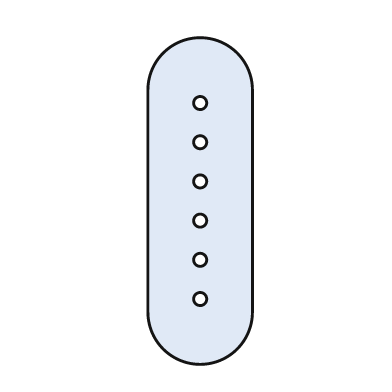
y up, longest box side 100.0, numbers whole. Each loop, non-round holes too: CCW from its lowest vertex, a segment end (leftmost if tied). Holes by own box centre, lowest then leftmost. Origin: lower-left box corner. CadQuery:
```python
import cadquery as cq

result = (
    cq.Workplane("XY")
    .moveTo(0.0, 16.0)
    .threePointArc((16.0, 0.0), (32.0, 16.0))
    .lineTo(32.0, 84.0)
    .threePointArc((16.0, 100.0), (0.0, 84.0))
    .close()
    .moveTo(16.0, 20.0)
    .circle(2.0)
    .moveTo(16.0, 32.0)
    .circle(2.0)
    .moveTo(16.0, 44.0)
    .circle(2.0)
    .moveTo(16.0, 56.0)
    .circle(2.0)
    .moveTo(16.0, 68.0)
    .circle(2.0)
    .moveTo(16.0, 80.0)
    .circle(2.0)
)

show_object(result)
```